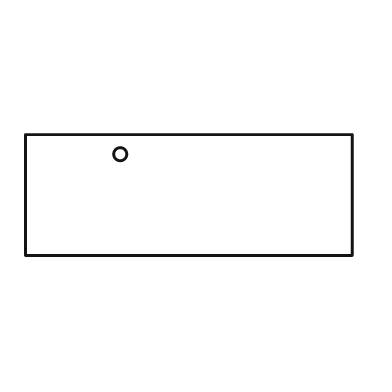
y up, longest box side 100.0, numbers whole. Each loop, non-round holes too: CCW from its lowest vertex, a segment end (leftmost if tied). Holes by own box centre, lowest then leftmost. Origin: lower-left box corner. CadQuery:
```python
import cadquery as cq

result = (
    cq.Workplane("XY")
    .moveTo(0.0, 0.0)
    .lineTo(100.0, 0.0)
    .lineTo(100.0, 37.0)
    .lineTo(0.0, 37.0)
    .close()
    .moveTo(29.0, 31.0)
    .circle(2.0)
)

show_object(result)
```